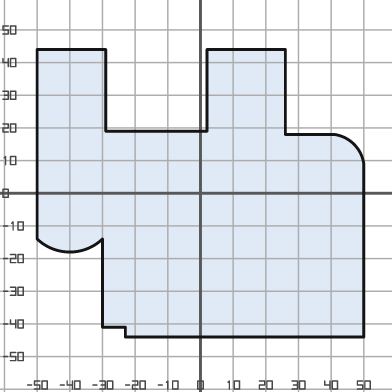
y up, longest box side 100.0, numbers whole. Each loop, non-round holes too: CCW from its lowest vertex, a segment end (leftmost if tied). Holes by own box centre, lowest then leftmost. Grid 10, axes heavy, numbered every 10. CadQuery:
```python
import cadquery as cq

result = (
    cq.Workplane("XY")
    .moveTo(-23.0, -44.0)
    .lineTo(50.0, -44.0)
    .lineTo(50.0, 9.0)
    .threePointArc((47.0, 15.0), (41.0, 18.0))
    .lineTo(26.0, 18.0)
    .lineTo(26.0, 44.0)
    .lineTo(2.0, 44.0)
    .lineTo(2.0, 19.0)
    .lineTo(-29.0, 19.0)
    .lineTo(-29.0, 44.0)
    .lineTo(-50.0, 44.0)
    .lineTo(-50.0, -14.0)
    .threePointArc((-40.0, -18.0), (-30.0, -14.0))
    .lineTo(-30.0, -41.0)
    .lineTo(-23.0, -41.0)
    .close()
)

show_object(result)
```